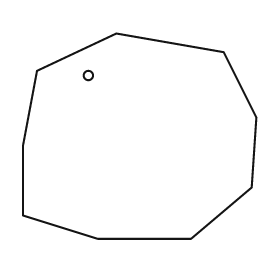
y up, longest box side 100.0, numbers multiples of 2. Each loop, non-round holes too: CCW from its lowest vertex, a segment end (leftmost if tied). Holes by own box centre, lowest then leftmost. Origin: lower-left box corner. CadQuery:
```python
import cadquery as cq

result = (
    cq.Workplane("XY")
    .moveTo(32.0, 0.0)
    .lineTo(72.0, 0.0)
    .lineTo(98.0, 22.0)
    .lineTo(100.0, 52.0)
    .lineTo(86.0, 80.0)
    .lineTo(40.0, 88.0)
    .lineTo(6.0, 72.0)
    .lineTo(0.0, 40.0)
    .lineTo(0.0, 10.0)
    .close()
    .moveTo(28.0, 70.0)
    .circle(2.0)
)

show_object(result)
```